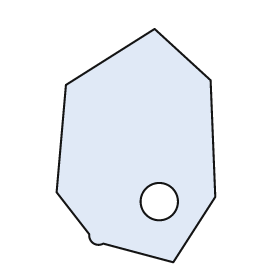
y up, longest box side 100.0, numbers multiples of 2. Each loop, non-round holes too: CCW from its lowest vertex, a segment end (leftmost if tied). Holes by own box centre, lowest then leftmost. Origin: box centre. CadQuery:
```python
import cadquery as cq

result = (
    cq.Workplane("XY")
    .moveTo(16.0, -50.0)
    .lineTo(34.0, -22.0)
    .lineTo(32.0, 28.0)
    .lineTo(8.0, 50.0)
    .lineTo(-30.0, 26.0)
    .lineTo(-34.0, -20.0)
    .lineTo(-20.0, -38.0)
    .threePointArc((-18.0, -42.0), (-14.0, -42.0))
    .close()
    .moveTo(10.0, -24.0)
    .circle(8.0)
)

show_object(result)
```